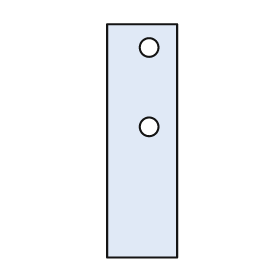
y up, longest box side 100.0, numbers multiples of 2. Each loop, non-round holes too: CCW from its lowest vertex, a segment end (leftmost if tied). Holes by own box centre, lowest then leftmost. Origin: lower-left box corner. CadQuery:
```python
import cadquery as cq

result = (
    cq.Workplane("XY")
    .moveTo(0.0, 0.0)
    .lineTo(30.0, 0.0)
    .lineTo(30.0, 100.0)
    .lineTo(0.0, 100.0)
    .close()
    .moveTo(18.0, 56.0)
    .circle(4.0)
    .moveTo(18.0, 90.0)
    .circle(4.0)
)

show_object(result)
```